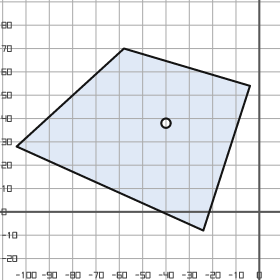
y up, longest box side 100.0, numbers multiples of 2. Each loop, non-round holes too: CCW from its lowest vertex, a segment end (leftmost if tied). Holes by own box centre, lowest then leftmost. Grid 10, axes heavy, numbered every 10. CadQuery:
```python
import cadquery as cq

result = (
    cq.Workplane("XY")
    .moveTo(-24.0, -8.0)
    .lineTo(-4.0, 54.0)
    .lineTo(-58.0, 70.0)
    .lineTo(-104.0, 28.0)
    .close()
    .moveTo(-40.0, 38.0)
    .circle(2.0)
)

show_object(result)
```